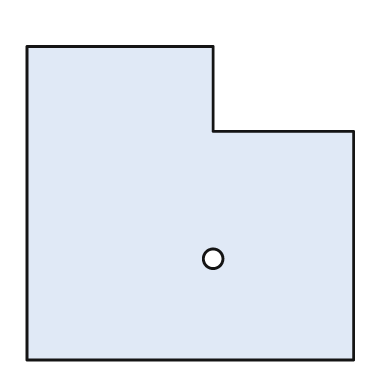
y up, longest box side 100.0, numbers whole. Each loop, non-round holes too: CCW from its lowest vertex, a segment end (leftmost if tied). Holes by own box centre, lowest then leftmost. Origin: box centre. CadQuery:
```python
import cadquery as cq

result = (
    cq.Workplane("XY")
    .moveTo(-50.0, -48.0)
    .lineTo(50.0, -48.0)
    .lineTo(50.0, 22.0)
    .lineTo(7.0, 22.0)
    .lineTo(7.0, 48.0)
    .lineTo(-50.0, 48.0)
    .close()
    .moveTo(7.0, -17.0)
    .circle(3.0)
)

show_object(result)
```